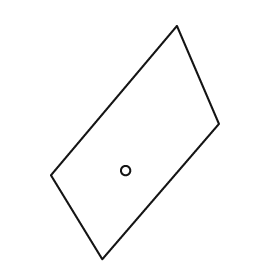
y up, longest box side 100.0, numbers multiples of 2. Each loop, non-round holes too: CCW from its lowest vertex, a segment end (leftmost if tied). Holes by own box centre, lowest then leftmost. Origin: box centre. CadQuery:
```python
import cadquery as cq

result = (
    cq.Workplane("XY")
    .moveTo(-14.0, -50.0)
    .lineTo(36.0, 8.0)
    .lineTo(18.0, 50.0)
    .lineTo(-36.0, -14.0)
    .close()
    .moveTo(-4.0, -12.0)
    .circle(2.0)
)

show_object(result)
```